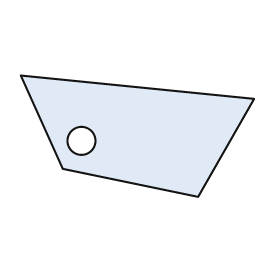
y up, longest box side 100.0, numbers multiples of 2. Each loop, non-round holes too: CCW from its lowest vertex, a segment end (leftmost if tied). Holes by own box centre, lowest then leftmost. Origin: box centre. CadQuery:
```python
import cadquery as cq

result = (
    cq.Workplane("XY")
    .moveTo(26.0, -26.0)
    .lineTo(50.0, 16.0)
    .lineTo(-50.0, 26.0)
    .lineTo(-32.0, -14.0)
    .close()
    .moveTo(-24.0, -2.0)
    .circle(6.0)
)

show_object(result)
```